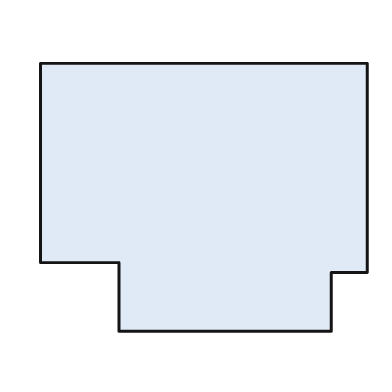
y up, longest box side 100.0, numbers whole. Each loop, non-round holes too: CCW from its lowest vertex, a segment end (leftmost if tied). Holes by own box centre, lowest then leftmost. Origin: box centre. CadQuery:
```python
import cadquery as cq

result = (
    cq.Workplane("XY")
    .moveTo(-26.0, -41.0)
    .lineTo(39.0, -41.0)
    .lineTo(39.0, -23.0)
    .lineTo(50.0, -23.0)
    .lineTo(50.0, 41.0)
    .lineTo(-50.0, 41.0)
    .lineTo(-50.0, -20.0)
    .lineTo(-26.0, -20.0)
    .close()
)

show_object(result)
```